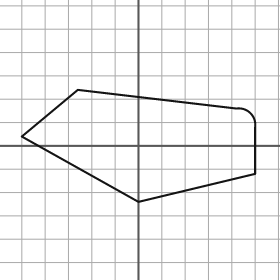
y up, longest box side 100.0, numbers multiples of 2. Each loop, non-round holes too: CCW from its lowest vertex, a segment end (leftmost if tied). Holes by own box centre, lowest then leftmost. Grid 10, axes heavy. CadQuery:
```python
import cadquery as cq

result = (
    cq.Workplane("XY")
    .moveTo(0.0, -24.0)
    .lineTo(50.0, -12.0)
    .lineTo(50.0, 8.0)
    .threePointArc((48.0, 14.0), (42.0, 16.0))
    .lineTo(-26.0, 24.0)
    .lineTo(-50.0, 4.0)
    .close()
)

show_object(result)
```